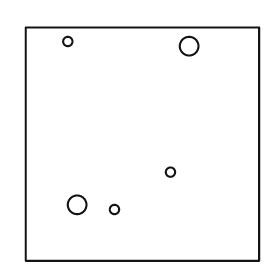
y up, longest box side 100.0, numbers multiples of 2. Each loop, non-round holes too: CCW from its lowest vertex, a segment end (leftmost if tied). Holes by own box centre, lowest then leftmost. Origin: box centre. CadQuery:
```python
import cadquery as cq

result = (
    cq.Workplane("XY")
    .moveTo(-50.0, -50.0)
    .lineTo(50.0, -50.0)
    .lineTo(50.0, 50.0)
    .lineTo(-50.0, 50.0)
    .close()
    .moveTo(-12.0, -28.0)
    .circle(2.0)
    .moveTo(-28.0, -26.0)
    .circle(4.0)
    .moveTo(12.0, -12.0)
    .circle(2.0)
    .moveTo(20.0, 42.0)
    .circle(4.0)
    .moveTo(-32.0, 44.0)
    .circle(2.0)
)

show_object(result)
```